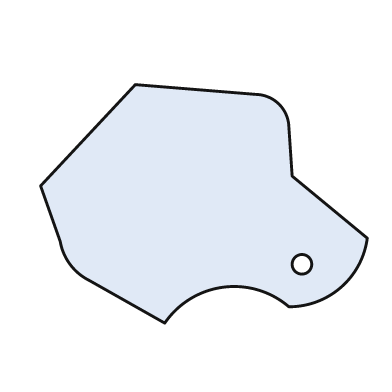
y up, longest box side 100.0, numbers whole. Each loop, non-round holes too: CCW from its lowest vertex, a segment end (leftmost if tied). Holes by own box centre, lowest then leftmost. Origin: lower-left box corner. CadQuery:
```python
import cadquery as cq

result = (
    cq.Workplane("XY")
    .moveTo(38.0, 0.0)
    .threePointArc((56.0, 11.0), (76.0, 5.0))
    .threePointArc((92.0, 11.0), (100.0, 26.0))
    .lineTo(77.0, 45.0)
    .lineTo(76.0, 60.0)
    .threePointArc((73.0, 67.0), (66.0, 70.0))
    .lineTo(29.0, 73.0)
    .lineTo(0.0, 42.0)
    .lineTo(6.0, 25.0)
    .threePointArc((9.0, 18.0), (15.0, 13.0))
    .close()
    .moveTo(80.0, 18.0)
    .circle(3.0)
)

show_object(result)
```